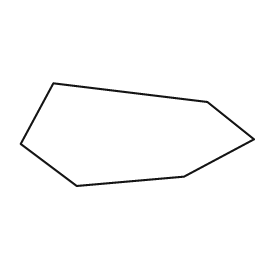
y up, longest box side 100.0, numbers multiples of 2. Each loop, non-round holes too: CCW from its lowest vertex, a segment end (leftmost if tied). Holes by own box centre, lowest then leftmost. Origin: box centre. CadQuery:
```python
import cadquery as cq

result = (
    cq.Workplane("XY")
    .moveTo(-26.0, -22.0)
    .lineTo(20.0, -18.0)
    .lineTo(50.0, -2.0)
    .lineTo(30.0, 14.0)
    .lineTo(-36.0, 22.0)
    .lineTo(-50.0, -4.0)
    .close()
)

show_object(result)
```